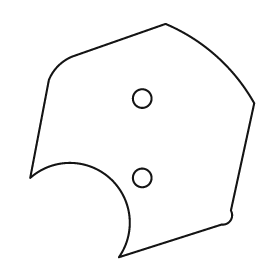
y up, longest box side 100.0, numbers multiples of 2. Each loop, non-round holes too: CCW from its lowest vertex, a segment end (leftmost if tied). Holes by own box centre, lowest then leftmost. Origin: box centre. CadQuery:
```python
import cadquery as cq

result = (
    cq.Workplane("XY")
    .moveTo(-10.0, -50.0)
    .lineTo(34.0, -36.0)
    .threePointArc((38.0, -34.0), (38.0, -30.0))
    .lineTo(48.0, 16.0)
    .threePointArc((32.0, 36.0), (10.0, 50.0))
    .lineTo(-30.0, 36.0)
    .threePointArc((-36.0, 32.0), (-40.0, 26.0))
    .lineTo(-48.0, -16.0)
    .threePointArc((-14.0, -16.0), (-10.0, -50.0))
    .close()
    .moveTo(0.0, -16.0)
    .circle(4.0)
    .moveTo(0.0, 18.0)
    .circle(4.0)
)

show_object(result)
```